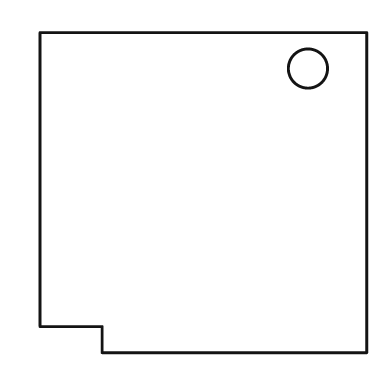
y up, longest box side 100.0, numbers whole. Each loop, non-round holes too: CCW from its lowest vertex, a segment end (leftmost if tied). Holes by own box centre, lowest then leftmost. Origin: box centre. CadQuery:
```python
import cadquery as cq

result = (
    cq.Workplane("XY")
    .moveTo(-31.0, -49.0)
    .lineTo(50.0, -49.0)
    .lineTo(50.0, 49.0)
    .lineTo(-50.0, 49.0)
    .lineTo(-50.0, -41.0)
    .lineTo(-31.0, -41.0)
    .close()
    .moveTo(32.0, 38.0)
    .circle(6.0)
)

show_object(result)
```